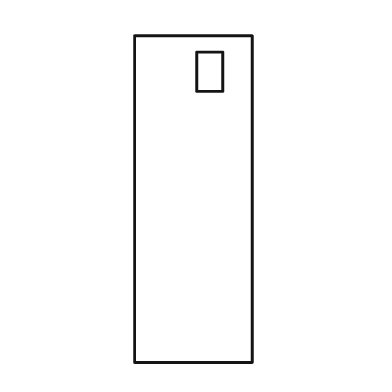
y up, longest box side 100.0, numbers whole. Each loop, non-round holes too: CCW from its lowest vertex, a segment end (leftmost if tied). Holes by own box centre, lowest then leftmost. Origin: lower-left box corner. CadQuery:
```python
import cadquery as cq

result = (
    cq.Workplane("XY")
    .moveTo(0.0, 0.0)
    .lineTo(36.0, 0.0)
    .lineTo(36.0, 100.0)
    .lineTo(0.0, 100.0)
    .close()
    .moveTo(19.0, 83.0)
    .lineTo(27.0, 83.0)
    .lineTo(27.0, 95.0)
    .lineTo(19.0, 95.0)
    .close()
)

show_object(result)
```